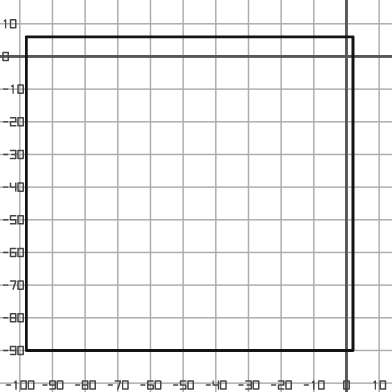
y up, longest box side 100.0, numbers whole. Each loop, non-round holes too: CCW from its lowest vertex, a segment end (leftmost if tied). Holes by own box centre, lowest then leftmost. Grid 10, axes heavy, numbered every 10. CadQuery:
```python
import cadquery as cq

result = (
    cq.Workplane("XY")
    .moveTo(-98.0, -90.0)
    .lineTo(2.0, -90.0)
    .lineTo(2.0, 6.0)
    .lineTo(-98.0, 6.0)
    .close()
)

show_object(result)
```